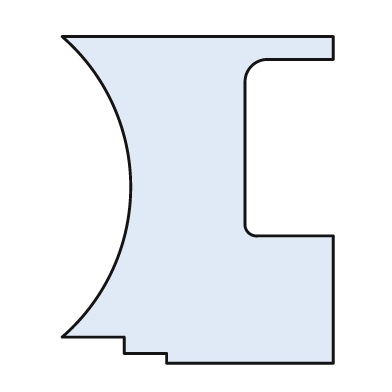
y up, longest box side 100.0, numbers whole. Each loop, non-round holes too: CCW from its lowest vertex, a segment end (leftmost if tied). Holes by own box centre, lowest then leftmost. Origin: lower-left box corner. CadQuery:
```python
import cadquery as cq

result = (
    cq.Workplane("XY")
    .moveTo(32.0, 0.0)
    .lineTo(83.0, 0.0)
    .lineTo(83.0, 39.0)
    .lineTo(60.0, 39.0)
    .threePointArc((57.0, 40.0), (56.0, 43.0))
    .lineTo(56.0, 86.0)
    .threePointArc((58.0, 91.0), (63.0, 93.0))
    .lineTo(83.0, 93.0)
    .lineTo(83.0, 100.0)
    .lineTo(0.0, 100.0)
    .threePointArc((21.0, 54.0), (0.0, 8.0))
    .lineTo(19.0, 8.0)
    .lineTo(19.0, 3.0)
    .lineTo(32.0, 3.0)
    .close()
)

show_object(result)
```